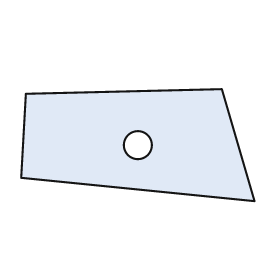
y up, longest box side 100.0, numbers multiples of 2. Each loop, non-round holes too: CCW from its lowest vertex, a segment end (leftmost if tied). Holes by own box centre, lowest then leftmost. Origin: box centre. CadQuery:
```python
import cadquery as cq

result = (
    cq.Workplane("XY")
    .moveTo(50.0, -24.0)
    .lineTo(36.0, 24.0)
    .lineTo(-48.0, 22.0)
    .lineTo(-50.0, -14.0)
    .close()
    .moveTo(0.0, 0.0)
    .circle(6.0)
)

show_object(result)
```